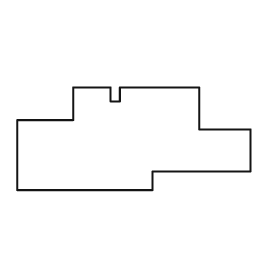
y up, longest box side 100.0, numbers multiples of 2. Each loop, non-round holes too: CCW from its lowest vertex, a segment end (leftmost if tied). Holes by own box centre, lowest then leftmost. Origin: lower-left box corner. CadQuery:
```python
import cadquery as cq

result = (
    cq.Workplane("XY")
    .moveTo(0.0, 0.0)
    .lineTo(58.0, 0.0)
    .lineTo(58.0, 8.0)
    .lineTo(100.0, 8.0)
    .lineTo(100.0, 26.0)
    .lineTo(78.0, 26.0)
    .lineTo(78.0, 44.0)
    .lineTo(44.0, 44.0)
    .lineTo(44.0, 38.0)
    .lineTo(40.0, 38.0)
    .lineTo(40.0, 44.0)
    .lineTo(24.0, 44.0)
    .lineTo(24.0, 30.0)
    .lineTo(0.0, 30.0)
    .close()
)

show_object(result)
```